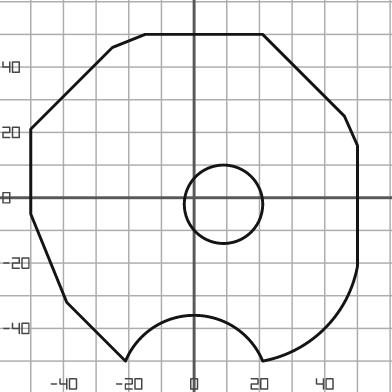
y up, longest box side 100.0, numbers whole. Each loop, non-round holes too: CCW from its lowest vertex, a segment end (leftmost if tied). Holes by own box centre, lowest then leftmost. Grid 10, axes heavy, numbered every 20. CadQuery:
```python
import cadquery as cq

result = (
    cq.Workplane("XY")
    .moveTo(-21.0, -50.0)
    .threePointArc((0.0, -36.0), (21.0, -50.0))
    .threePointArc((40.0, -40.0), (50.0, -21.0))
    .lineTo(50.0, 16.0)
    .lineTo(46.0, 25.0)
    .lineTo(21.0, 50.0)
    .lineTo(-15.0, 50.0)
    .lineTo(-25.0, 46.0)
    .lineTo(-50.0, 21.0)
    .lineTo(-50.0, -5.0)
    .lineTo(-39.0, -32.0)
    .close()
    .moveTo(9.0, -2.0)
    .circle(12.0)
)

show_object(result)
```